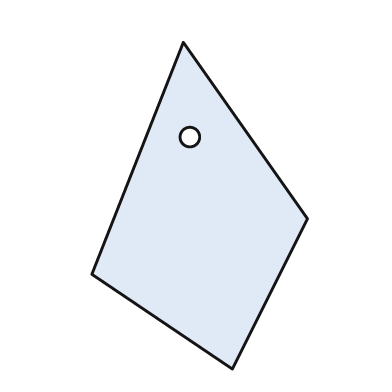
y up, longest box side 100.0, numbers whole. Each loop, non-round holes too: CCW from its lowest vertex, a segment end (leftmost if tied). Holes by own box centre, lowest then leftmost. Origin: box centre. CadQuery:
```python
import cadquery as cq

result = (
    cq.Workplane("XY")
    .moveTo(10.0, -50.0)
    .lineTo(33.0, -4.0)
    .lineTo(-5.0, 50.0)
    .lineTo(-33.0, -21.0)
    .close()
    .moveTo(-3.0, 21.0)
    .circle(3.0)
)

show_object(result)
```